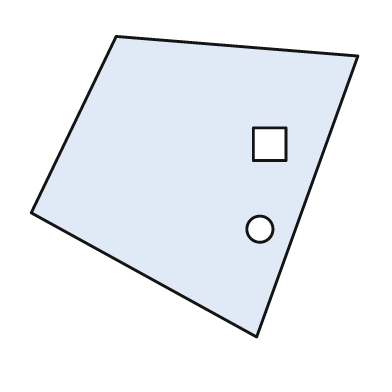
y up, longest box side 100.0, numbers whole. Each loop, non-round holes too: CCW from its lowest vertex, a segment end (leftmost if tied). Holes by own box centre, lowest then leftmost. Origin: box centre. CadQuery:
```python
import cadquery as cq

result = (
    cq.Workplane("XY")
    .moveTo(19.0, -46.0)
    .lineTo(50.0, 40.0)
    .lineTo(-24.0, 46.0)
    .lineTo(-50.0, -8.0)
    .close()
    .moveTo(20.0, -13.0)
    .circle(4.0)
    .moveTo(18.0, 8.0)
    .lineTo(28.0, 8.0)
    .lineTo(28.0, 18.0)
    .lineTo(18.0, 18.0)
    .close()
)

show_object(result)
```